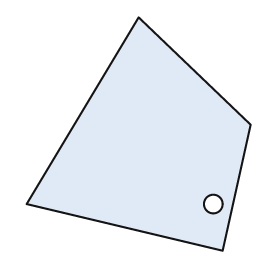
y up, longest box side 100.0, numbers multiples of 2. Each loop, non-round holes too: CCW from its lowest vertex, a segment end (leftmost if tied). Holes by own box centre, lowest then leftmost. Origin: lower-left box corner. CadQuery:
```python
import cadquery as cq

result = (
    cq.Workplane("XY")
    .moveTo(84.0, 0.0)
    .lineTo(96.0, 54.0)
    .lineTo(48.0, 100.0)
    .lineTo(0.0, 20.0)
    .close()
    .moveTo(80.0, 20.0)
    .circle(4.0)
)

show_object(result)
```